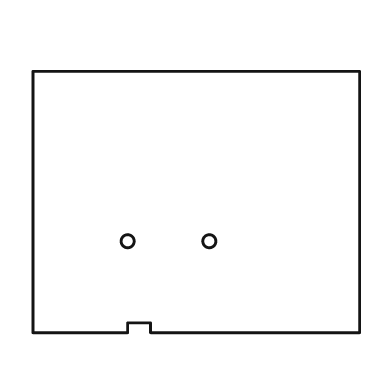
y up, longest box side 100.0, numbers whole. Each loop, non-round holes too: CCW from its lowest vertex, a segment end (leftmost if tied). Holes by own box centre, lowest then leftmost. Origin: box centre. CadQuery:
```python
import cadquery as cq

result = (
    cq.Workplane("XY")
    .moveTo(-50.0, -40.0)
    .lineTo(-21.0, -40.0)
    .lineTo(-21.0, -37.0)
    .lineTo(-14.0, -37.0)
    .lineTo(-14.0, -40.0)
    .lineTo(50.0, -40.0)
    .lineTo(50.0, 40.0)
    .lineTo(-50.0, 40.0)
    .close()
    .moveTo(-21.0, -12.0)
    .circle(2.0)
    .moveTo(4.0, -12.0)
    .circle(2.0)
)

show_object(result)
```